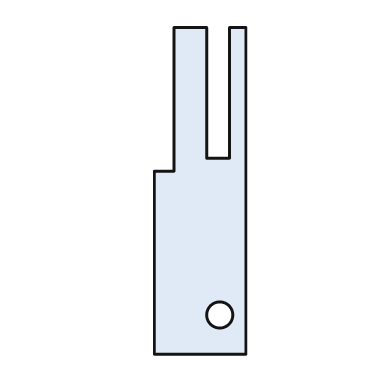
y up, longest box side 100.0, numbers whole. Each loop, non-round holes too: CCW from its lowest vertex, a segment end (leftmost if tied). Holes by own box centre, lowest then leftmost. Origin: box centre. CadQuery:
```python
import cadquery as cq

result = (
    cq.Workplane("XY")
    .moveTo(-14.0, -50.0)
    .lineTo(14.0, -50.0)
    .lineTo(14.0, 50.0)
    .lineTo(9.0, 50.0)
    .lineTo(9.0, 10.0)
    .lineTo(2.0, 10.0)
    .lineTo(2.0, 50.0)
    .lineTo(-8.0, 50.0)
    .lineTo(-8.0, 6.0)
    .lineTo(-14.0, 6.0)
    .close()
    .moveTo(6.0, -38.0)
    .circle(4.0)
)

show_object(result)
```